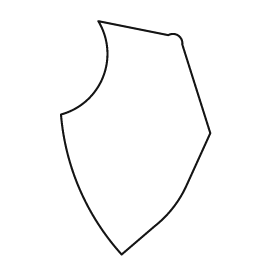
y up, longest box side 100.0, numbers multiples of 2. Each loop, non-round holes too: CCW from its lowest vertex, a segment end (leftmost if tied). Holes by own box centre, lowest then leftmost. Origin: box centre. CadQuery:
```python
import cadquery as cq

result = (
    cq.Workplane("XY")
    .moveTo(-6.0, -50.0)
    .lineTo(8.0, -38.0)
    .threePointArc((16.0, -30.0), (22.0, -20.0))
    .lineTo(32.0, 2.0)
    .lineTo(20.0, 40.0)
    .threePointArc((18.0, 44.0), (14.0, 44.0))
    .lineTo(-16.0, 50.0)
    .threePointArc((-14.0, 26.0), (-32.0, 10.0))
    .threePointArc((-24.0, -22.0), (-6.0, -50.0))
    .close()
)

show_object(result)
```